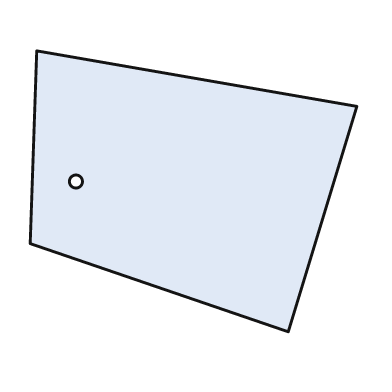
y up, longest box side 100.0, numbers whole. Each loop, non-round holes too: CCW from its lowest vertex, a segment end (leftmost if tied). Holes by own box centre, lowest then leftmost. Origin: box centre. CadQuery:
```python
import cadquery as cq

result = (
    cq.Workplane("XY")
    .moveTo(29.0, -43.0)
    .lineTo(50.0, 26.0)
    .lineTo(-48.0, 43.0)
    .lineTo(-50.0, -16.0)
    .close()
    .moveTo(-36.0, 3.0)
    .circle(2.0)
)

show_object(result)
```